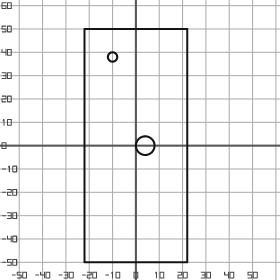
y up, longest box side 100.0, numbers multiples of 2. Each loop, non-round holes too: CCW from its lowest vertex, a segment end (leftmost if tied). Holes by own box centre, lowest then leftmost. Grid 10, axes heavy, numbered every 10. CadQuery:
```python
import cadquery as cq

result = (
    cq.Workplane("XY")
    .moveTo(-22.0, -50.0)
    .lineTo(22.0, -50.0)
    .lineTo(22.0, 50.0)
    .lineTo(-22.0, 50.0)
    .close()
    .moveTo(4.0, 0.0)
    .circle(4.0)
    .moveTo(-10.0, 38.0)
    .circle(2.0)
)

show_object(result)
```